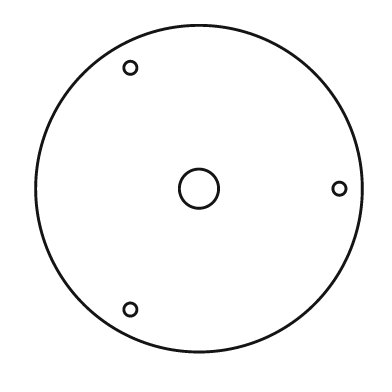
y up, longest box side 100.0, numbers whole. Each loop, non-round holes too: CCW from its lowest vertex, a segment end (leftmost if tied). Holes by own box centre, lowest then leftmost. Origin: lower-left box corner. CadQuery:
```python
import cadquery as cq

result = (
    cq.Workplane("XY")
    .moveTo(50.0, 50.0)
    .circle(50.0)
    .moveTo(29.0, 13.0)
    .circle(2.0)
    .moveTo(50.0, 50.0)
    .circle(6.0)
    .moveTo(93.0, 50.0)
    .circle(2.0)
    .moveTo(29.0, 87.0)
    .circle(2.0)
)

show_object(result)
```